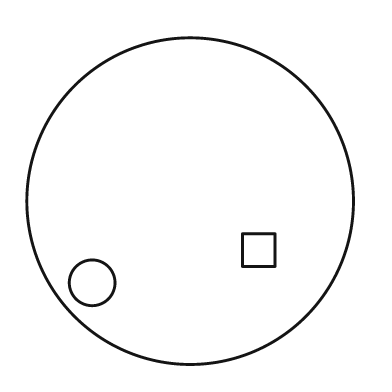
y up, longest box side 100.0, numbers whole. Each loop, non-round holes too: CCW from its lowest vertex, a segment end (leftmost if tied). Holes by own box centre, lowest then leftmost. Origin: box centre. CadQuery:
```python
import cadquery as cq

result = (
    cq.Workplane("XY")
    .moveTo(0.0, 0.0)
    .circle(50.0)
    .moveTo(-30.0, -25.0)
    .circle(7.0)
    .moveTo(16.0, -20.0)
    .lineTo(26.0, -20.0)
    .lineTo(26.0, -10.0)
    .lineTo(16.0, -10.0)
    .close()
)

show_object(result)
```